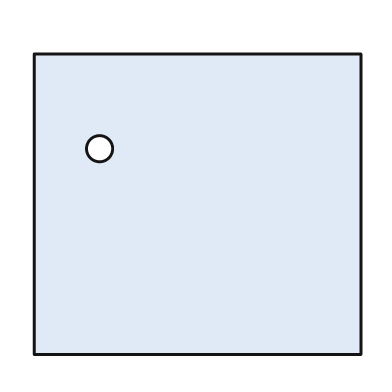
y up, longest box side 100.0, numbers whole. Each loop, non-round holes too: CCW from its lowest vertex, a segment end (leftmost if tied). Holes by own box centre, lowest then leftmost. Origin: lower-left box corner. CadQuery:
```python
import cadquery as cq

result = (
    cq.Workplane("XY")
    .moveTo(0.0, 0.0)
    .lineTo(100.0, 0.0)
    .lineTo(100.0, 92.0)
    .lineTo(0.0, 92.0)
    .close()
    .moveTo(20.0, 63.0)
    .circle(4.0)
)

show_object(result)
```